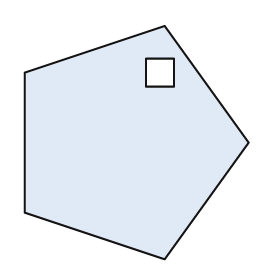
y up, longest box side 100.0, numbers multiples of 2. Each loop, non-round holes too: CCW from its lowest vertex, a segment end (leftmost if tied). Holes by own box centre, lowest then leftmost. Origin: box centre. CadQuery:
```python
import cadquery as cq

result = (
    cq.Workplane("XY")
    .moveTo(12.0, -50.0)
    .lineTo(48.0, 0.0)
    .lineTo(12.0, 50.0)
    .lineTo(-48.0, 30.0)
    .lineTo(-48.0, -30.0)
    .close()
    .moveTo(4.0, 24.0)
    .lineTo(16.0, 24.0)
    .lineTo(16.0, 36.0)
    .lineTo(4.0, 36.0)
    .close()
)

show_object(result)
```